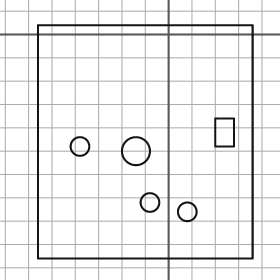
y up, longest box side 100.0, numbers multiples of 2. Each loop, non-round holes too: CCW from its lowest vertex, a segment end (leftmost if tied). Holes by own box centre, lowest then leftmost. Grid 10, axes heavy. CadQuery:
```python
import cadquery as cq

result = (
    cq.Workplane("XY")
    .moveTo(-56.0, -96.0)
    .lineTo(36.0, -96.0)
    .lineTo(36.0, 4.0)
    .lineTo(-56.0, 4.0)
    .close()
    .moveTo(8.0, -76.0)
    .circle(4.0)
    .moveTo(-8.0, -72.0)
    .circle(4.0)
    .moveTo(-14.0, -50.0)
    .circle(6.0)
    .moveTo(-38.0, -48.0)
    .circle(4.0)
    .moveTo(20.0, -48.0)
    .lineTo(28.0, -48.0)
    .lineTo(28.0, -36.0)
    .lineTo(20.0, -36.0)
    .close()
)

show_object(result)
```